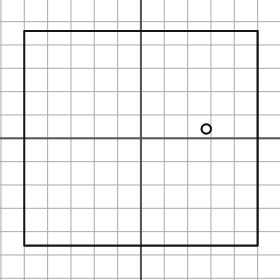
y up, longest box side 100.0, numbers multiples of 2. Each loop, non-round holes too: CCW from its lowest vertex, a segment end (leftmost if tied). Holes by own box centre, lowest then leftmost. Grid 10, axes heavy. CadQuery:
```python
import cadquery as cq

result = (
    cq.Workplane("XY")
    .moveTo(-50.0, -46.0)
    .lineTo(50.0, -46.0)
    .lineTo(50.0, 46.0)
    .lineTo(-50.0, 46.0)
    .close()
    .moveTo(28.0, 4.0)
    .circle(2.0)
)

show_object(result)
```